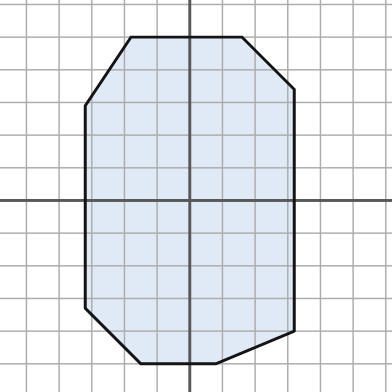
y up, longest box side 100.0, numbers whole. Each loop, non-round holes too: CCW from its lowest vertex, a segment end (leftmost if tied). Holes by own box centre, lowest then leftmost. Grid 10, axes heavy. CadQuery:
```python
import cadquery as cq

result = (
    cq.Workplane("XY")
    .moveTo(-15.0, -50.0)
    .lineTo(8.0, -50.0)
    .lineTo(32.0, -40.0)
    .lineTo(32.0, 34.0)
    .lineTo(16.0, 50.0)
    .lineTo(-18.0, 50.0)
    .lineTo(-32.0, 29.0)
    .lineTo(-32.0, -33.0)
    .close()
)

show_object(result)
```